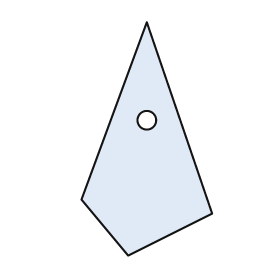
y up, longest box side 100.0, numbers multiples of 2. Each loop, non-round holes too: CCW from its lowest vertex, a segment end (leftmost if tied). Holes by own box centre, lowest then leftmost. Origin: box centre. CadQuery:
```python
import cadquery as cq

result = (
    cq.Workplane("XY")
    .moveTo(-8.0, -50.0)
    .lineTo(28.0, -32.0)
    .lineTo(0.0, 50.0)
    .lineTo(-28.0, -26.0)
    .close()
    .moveTo(0.0, 8.0)
    .circle(4.0)
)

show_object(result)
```